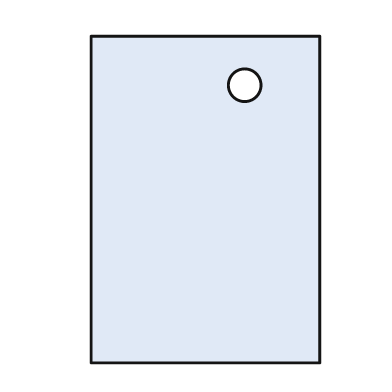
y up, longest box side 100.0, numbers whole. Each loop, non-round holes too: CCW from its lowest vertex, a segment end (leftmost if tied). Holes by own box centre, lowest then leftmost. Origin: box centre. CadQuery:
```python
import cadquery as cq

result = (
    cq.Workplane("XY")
    .moveTo(-35.0, -50.0)
    .lineTo(35.0, -50.0)
    .lineTo(35.0, 50.0)
    .lineTo(-35.0, 50.0)
    .close()
    .moveTo(12.0, 35.0)
    .circle(5.0)
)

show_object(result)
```